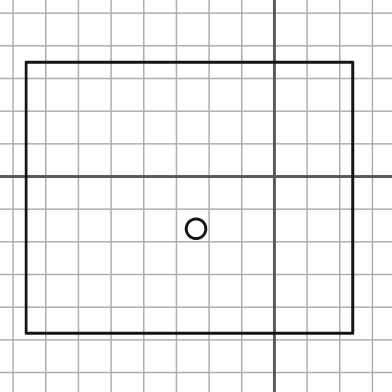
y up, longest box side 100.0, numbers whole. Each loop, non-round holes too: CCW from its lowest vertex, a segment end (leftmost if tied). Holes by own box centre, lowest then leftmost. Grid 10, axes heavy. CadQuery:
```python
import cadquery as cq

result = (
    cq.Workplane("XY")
    .moveTo(-76.0, -48.0)
    .lineTo(24.0, -48.0)
    .lineTo(24.0, 35.0)
    .lineTo(-76.0, 35.0)
    .close()
    .moveTo(-24.0, -16.0)
    .circle(3.0)
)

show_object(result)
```